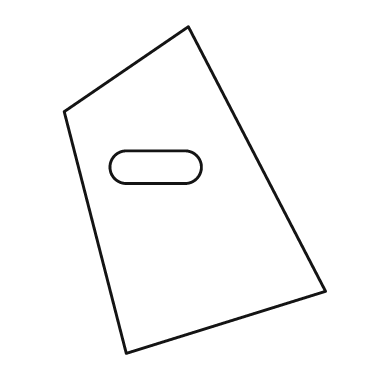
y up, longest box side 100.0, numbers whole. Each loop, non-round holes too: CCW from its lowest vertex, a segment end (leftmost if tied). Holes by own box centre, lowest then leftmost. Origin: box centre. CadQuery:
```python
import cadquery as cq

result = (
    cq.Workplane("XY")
    .moveTo(-21.0, -50.0)
    .lineTo(40.0, -31.0)
    .lineTo(-2.0, 50.0)
    .lineTo(-40.0, 24.0)
    .close()
    .moveTo(-21.0, 2.0)
    .lineTo(-3.0, 2.0)
    .threePointArc((2.0, 7.0), (-3.0, 12.0))
    .lineTo(-21.0, 12.0)
    .threePointArc((-26.0, 7.0), (-21.0, 2.0))
    .close()
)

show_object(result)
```